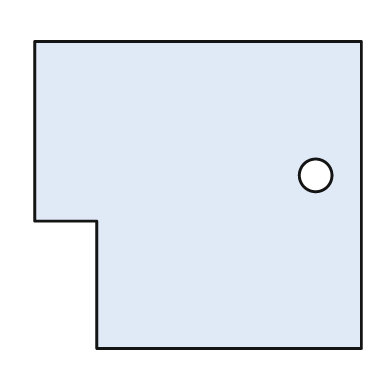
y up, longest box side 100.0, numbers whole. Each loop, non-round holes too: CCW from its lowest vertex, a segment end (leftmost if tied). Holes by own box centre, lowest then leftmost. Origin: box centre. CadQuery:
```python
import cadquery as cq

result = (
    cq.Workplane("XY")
    .moveTo(-31.0, -47.0)
    .lineTo(50.0, -47.0)
    .lineTo(50.0, 47.0)
    .lineTo(-50.0, 47.0)
    .lineTo(-50.0, -8.0)
    .lineTo(-31.0, -8.0)
    .close()
    .moveTo(36.0, 6.0)
    .circle(5.0)
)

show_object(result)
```